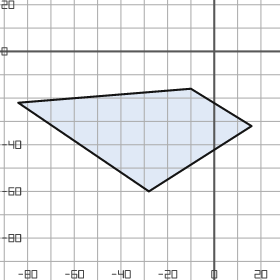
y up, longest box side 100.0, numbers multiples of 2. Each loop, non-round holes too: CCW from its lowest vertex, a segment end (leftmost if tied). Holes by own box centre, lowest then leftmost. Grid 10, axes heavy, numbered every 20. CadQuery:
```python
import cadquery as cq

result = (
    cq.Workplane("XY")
    .moveTo(-28.0, -60.0)
    .lineTo(16.0, -32.0)
    .lineTo(-10.0, -16.0)
    .lineTo(-84.0, -22.0)
    .close()
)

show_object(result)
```